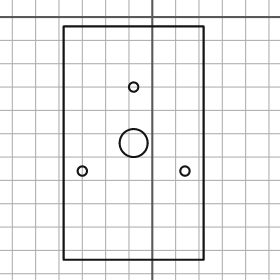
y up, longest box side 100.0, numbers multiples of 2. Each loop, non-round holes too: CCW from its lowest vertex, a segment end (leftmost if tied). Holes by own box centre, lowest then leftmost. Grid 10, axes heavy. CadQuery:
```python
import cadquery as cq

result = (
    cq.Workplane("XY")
    .moveTo(-38.0, -104.0)
    .lineTo(22.0, -104.0)
    .lineTo(22.0, -4.0)
    .lineTo(-38.0, -4.0)
    .close()
    .moveTo(-30.0, -66.0)
    .circle(2.0)
    .moveTo(14.0, -66.0)
    .circle(2.0)
    .moveTo(-8.0, -54.0)
    .circle(6.0)
    .moveTo(-8.0, -30.0)
    .circle(2.0)
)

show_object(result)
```